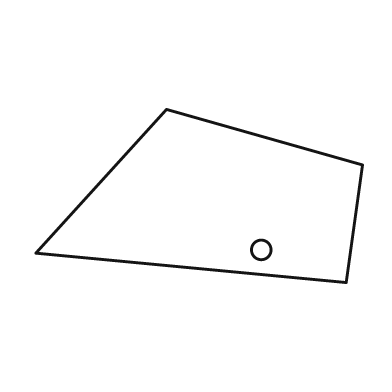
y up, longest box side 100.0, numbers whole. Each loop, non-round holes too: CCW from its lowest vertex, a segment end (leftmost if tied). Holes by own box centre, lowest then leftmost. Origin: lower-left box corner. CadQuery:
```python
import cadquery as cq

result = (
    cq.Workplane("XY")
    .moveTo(95.0, 0.0)
    .lineTo(100.0, 36.0)
    .lineTo(40.0, 53.0)
    .lineTo(0.0, 9.0)
    .close()
    .moveTo(69.0, 10.0)
    .circle(3.0)
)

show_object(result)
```